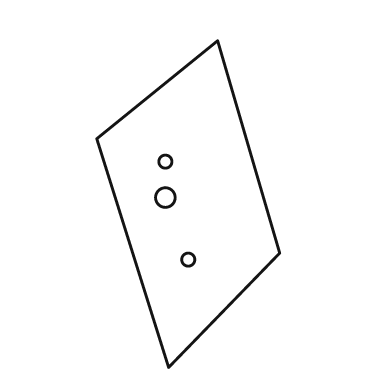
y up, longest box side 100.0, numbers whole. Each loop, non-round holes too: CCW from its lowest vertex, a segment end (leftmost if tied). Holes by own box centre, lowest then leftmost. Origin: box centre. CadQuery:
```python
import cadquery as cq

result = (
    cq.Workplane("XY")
    .moveTo(-6.0, -50.0)
    .lineTo(28.0, -15.0)
    .lineTo(9.0, 50.0)
    .lineTo(-28.0, 20.0)
    .close()
    .moveTo(0.0, -17.0)
    .circle(2.0)
    .moveTo(-7.0, 2.0)
    .circle(3.0)
    .moveTo(-7.0, 13.0)
    .circle(2.0)
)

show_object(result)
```